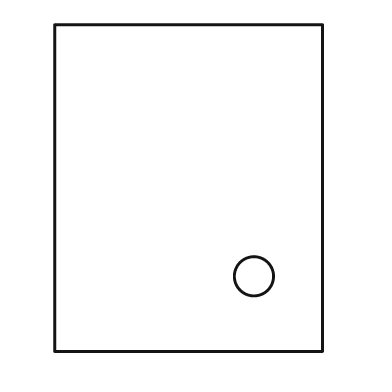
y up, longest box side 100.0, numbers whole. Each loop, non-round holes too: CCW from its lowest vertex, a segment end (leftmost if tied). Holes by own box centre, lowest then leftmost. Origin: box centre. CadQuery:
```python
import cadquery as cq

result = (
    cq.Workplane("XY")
    .moveTo(-41.0, -50.0)
    .lineTo(41.0, -50.0)
    .lineTo(41.0, 50.0)
    .lineTo(-41.0, 50.0)
    .close()
    .moveTo(20.0, -27.0)
    .circle(6.0)
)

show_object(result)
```